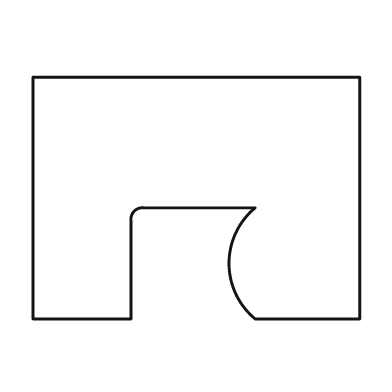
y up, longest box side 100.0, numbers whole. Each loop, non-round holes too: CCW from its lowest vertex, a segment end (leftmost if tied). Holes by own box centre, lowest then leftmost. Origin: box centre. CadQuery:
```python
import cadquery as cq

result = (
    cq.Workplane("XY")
    .moveTo(-50.0, -37.0)
    .lineTo(-20.0, -37.0)
    .lineTo(-20.0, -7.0)
    .threePointArc((-19.0, -4.0), (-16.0, -3.0))
    .lineTo(18.0, -3.0)
    .threePointArc((10.0, -20.0), (18.0, -37.0))
    .lineTo(50.0, -37.0)
    .lineTo(50.0, 37.0)
    .lineTo(-50.0, 37.0)
    .close()
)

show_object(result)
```